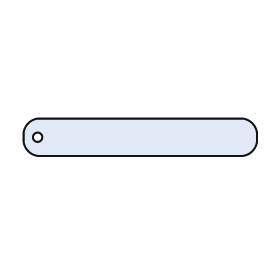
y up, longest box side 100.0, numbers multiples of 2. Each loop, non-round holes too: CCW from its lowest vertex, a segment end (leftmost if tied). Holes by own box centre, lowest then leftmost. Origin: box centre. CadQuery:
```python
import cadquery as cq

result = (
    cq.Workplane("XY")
    .moveTo(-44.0, -8.0)
    .lineTo(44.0, -8.0)
    .threePointArc((48.0, -6.0), (50.0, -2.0))
    .lineTo(50.0, 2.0)
    .threePointArc((48.0, 6.0), (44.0, 8.0))
    .lineTo(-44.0, 8.0)
    .threePointArc((-48.0, 6.0), (-50.0, 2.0))
    .lineTo(-50.0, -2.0)
    .threePointArc((-48.0, -6.0), (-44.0, -8.0))
    .close()
    .moveTo(-44.0, 0.0)
    .circle(2.0)
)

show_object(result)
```